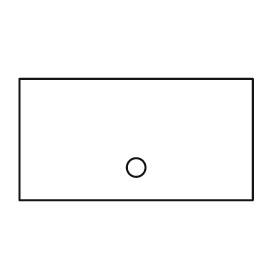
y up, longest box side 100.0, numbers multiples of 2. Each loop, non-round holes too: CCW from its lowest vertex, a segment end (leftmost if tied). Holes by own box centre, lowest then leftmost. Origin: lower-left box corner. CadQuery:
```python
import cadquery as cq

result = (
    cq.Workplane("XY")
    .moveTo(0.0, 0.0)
    .lineTo(100.0, 0.0)
    .lineTo(100.0, 52.0)
    .lineTo(0.0, 52.0)
    .close()
    .moveTo(50.0, 14.0)
    .circle(4.0)
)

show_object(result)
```